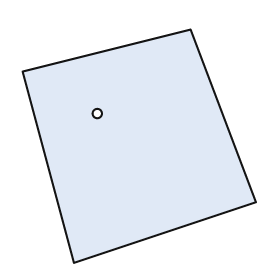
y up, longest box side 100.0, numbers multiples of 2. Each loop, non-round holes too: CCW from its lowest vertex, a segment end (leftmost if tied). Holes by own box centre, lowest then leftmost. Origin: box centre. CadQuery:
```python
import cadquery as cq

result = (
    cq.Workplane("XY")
    .moveTo(-28.0, -50.0)
    .lineTo(50.0, -24.0)
    .lineTo(22.0, 50.0)
    .lineTo(-50.0, 32.0)
    .close()
    .moveTo(-18.0, 14.0)
    .circle(2.0)
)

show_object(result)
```